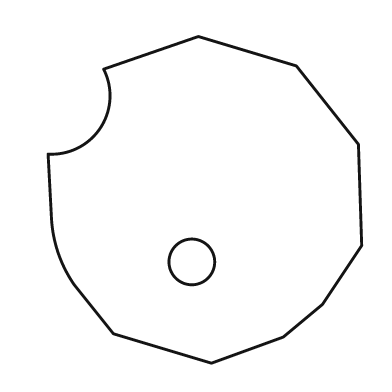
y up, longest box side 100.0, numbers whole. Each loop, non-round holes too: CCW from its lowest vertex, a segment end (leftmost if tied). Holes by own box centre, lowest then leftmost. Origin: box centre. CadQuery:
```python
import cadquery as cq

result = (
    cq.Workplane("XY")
    .moveTo(2.0, -50.0)
    .lineTo(24.0, -42.0)
    .lineTo(36.0, -32.0)
    .lineTo(48.0, -14.0)
    .lineTo(47.0, 17.0)
    .lineTo(28.0, 41.0)
    .lineTo(-2.0, 50.0)
    .lineTo(-31.0, 40.0)
    .threePointArc((-32.0, 22.0), (-48.0, 14.0))
    .lineTo(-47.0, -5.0)
    .threePointArc((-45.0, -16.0), (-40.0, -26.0))
    .lineTo(-28.0, -41.0)
    .close()
    .moveTo(-4.0, -19.0)
    .circle(7.0)
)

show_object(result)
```